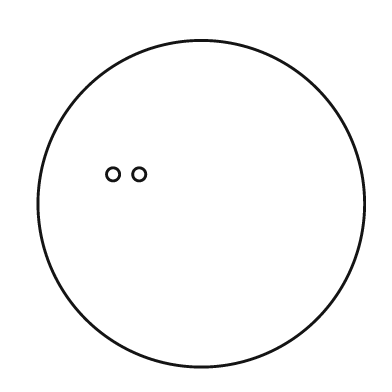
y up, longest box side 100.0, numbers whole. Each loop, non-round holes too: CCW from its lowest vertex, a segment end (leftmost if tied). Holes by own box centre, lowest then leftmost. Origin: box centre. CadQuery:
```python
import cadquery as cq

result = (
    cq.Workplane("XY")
    .moveTo(0.0, 0.0)
    .circle(50.0)
    .moveTo(-27.0, 9.0)
    .circle(2.0)
    .moveTo(-19.0, 9.0)
    .circle(2.0)
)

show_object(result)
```